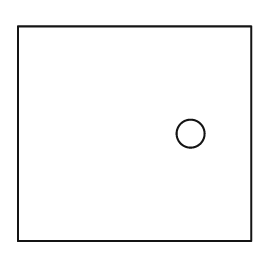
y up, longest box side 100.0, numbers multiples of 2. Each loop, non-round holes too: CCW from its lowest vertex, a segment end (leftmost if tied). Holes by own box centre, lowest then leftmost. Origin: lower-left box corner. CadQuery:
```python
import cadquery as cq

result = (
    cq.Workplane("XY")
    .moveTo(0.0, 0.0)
    .lineTo(100.0, 0.0)
    .lineTo(100.0, 92.0)
    .lineTo(0.0, 92.0)
    .close()
    .moveTo(74.0, 46.0)
    .circle(6.0)
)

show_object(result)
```